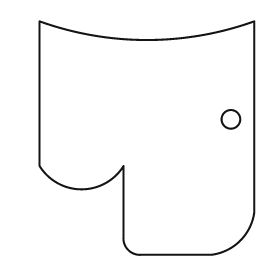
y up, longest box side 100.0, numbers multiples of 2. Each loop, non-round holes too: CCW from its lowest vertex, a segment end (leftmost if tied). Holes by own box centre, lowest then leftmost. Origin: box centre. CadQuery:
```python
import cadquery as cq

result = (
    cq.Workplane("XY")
    .moveTo(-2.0, -50.0)
    .lineTo(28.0, -50.0)
    .threePointArc((40.0, -44.0), (46.0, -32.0))
    .lineTo(46.0, 50.0)
    .threePointArc((0.0, 42.0), (-46.0, 50.0))
    .lineTo(-46.0, -12.0)
    .threePointArc((-28.0, -22.0), (-10.0, -12.0))
    .lineTo(-10.0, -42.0)
    .threePointArc((-8.0, -48.0), (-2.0, -50.0))
    .close()
    .moveTo(36.0, 8.0)
    .circle(4.0)
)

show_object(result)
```